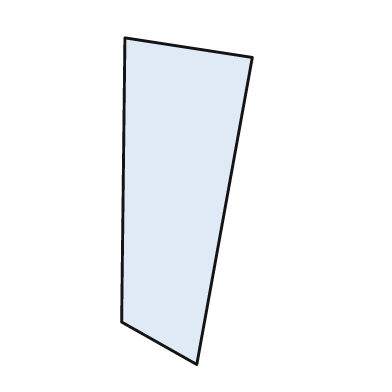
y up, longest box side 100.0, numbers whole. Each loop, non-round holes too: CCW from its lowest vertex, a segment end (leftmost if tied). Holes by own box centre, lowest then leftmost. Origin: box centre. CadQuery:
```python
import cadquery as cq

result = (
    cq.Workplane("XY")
    .moveTo(3.0, -50.0)
    .lineTo(20.0, 44.0)
    .lineTo(-19.0, 50.0)
    .lineTo(-20.0, -37.0)
    .close()
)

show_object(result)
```